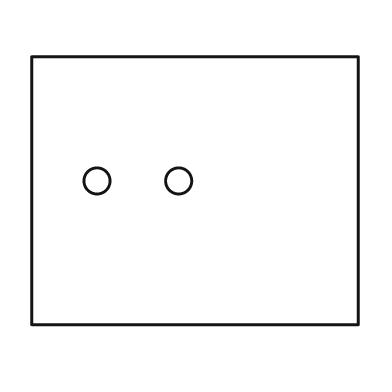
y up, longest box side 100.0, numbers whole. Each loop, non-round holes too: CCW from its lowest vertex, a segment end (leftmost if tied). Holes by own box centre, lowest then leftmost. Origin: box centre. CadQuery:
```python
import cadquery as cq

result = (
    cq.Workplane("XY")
    .moveTo(-50.0, -41.0)
    .lineTo(50.0, -41.0)
    .lineTo(50.0, 41.0)
    .lineTo(-50.0, 41.0)
    .close()
    .moveTo(-30.0, 3.0)
    .circle(4.0)
    .moveTo(-5.0, 3.0)
    .circle(4.0)
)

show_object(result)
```